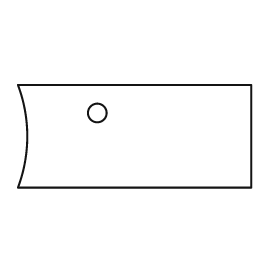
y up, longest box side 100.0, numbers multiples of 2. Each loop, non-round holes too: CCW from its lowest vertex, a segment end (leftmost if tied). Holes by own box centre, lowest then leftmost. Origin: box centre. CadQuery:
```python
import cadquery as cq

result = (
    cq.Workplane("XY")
    .moveTo(-50.0, -22.0)
    .lineTo(50.0, -22.0)
    .lineTo(50.0, 22.0)
    .lineTo(-50.0, 22.0)
    .threePointArc((-46.0, 0.0), (-50.0, -22.0))
    .close()
    .moveTo(-16.0, 10.0)
    .circle(4.0)
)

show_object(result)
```